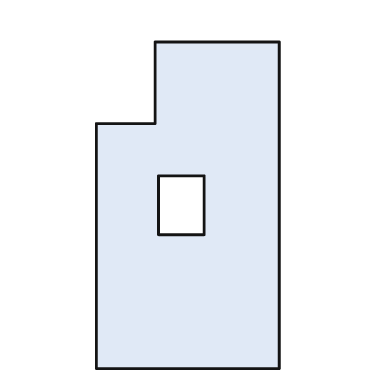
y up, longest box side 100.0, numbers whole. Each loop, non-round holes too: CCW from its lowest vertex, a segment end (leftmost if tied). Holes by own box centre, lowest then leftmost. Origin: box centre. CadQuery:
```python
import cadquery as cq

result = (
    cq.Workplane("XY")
    .moveTo(-28.0, -50.0)
    .lineTo(28.0, -50.0)
    .lineTo(28.0, 50.0)
    .lineTo(-10.0, 50.0)
    .lineTo(-10.0, 25.0)
    .lineTo(-28.0, 25.0)
    .close()
    .moveTo(-9.0, -9.0)
    .lineTo(5.0, -9.0)
    .lineTo(5.0, 9.0)
    .lineTo(-9.0, 9.0)
    .close()
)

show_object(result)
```